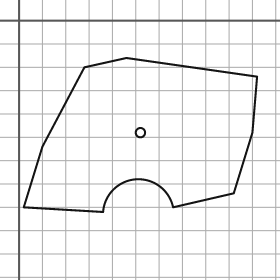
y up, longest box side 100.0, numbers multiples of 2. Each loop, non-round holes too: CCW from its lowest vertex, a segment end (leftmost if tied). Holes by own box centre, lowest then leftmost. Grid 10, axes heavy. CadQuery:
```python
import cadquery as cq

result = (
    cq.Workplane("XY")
    .moveTo(36.0, -82.0)
    .threePointArc((50.0, -68.0), (66.0, -80.0))
    .lineTo(92.0, -74.0)
    .lineTo(100.0, -48.0)
    .lineTo(102.0, -24.0)
    .lineTo(46.0, -16.0)
    .lineTo(28.0, -20.0)
    .lineTo(10.0, -54.0)
    .lineTo(2.0, -80.0)
    .close()
    .moveTo(52.0, -48.0)
    .circle(2.0)
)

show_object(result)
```